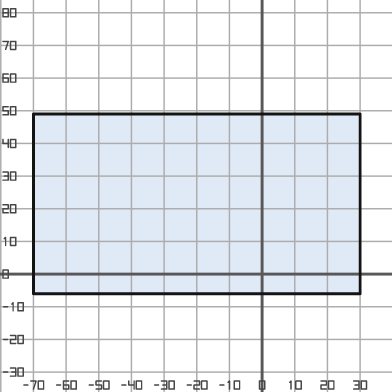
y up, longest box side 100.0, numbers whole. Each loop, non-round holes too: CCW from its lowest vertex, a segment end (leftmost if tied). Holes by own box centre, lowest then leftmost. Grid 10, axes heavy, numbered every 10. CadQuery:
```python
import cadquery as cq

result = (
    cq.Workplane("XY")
    .moveTo(-70.0, -6.0)
    .lineTo(30.0, -6.0)
    .lineTo(30.0, 49.0)
    .lineTo(-70.0, 49.0)
    .close()
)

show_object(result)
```